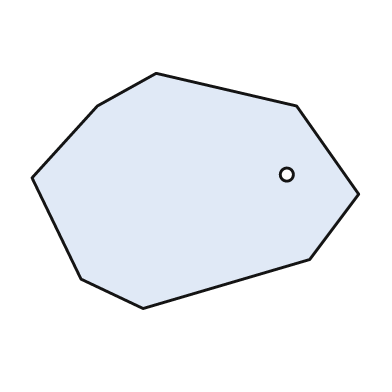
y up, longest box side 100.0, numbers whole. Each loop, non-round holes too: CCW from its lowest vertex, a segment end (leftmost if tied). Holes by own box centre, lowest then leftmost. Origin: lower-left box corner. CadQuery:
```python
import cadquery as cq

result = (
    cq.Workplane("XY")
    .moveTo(34.0, 0.0)
    .lineTo(85.0, 15.0)
    .lineTo(100.0, 35.0)
    .lineTo(81.0, 62.0)
    .lineTo(38.0, 72.0)
    .lineTo(20.0, 62.0)
    .lineTo(0.0, 40.0)
    .lineTo(15.0, 9.0)
    .close()
    .moveTo(78.0, 41.0)
    .circle(2.0)
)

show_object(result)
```